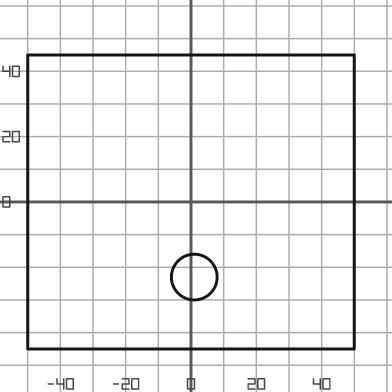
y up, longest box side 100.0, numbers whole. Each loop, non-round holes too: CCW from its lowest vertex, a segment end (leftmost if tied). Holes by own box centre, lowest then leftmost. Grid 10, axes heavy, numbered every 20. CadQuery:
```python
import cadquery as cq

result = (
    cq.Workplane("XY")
    .moveTo(-50.0, -45.0)
    .lineTo(50.0, -45.0)
    .lineTo(50.0, 45.0)
    .lineTo(-50.0, 45.0)
    .close()
    .moveTo(1.0, -23.0)
    .circle(7.0)
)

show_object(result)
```